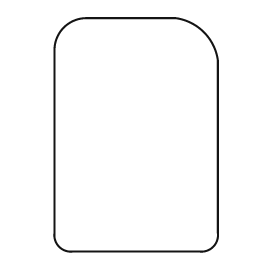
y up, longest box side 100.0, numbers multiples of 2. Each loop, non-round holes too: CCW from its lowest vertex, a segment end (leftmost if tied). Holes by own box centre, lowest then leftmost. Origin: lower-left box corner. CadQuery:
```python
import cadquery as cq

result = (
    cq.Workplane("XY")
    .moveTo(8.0, 0.0)
    .lineTo(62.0, 0.0)
    .threePointArc((68.0, 2.0), (70.0, 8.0))
    .lineTo(70.0, 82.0)
    .threePointArc((64.0, 94.0), (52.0, 100.0))
    .lineTo(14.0, 100.0)
    .threePointArc((4.0, 96.0), (0.0, 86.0))
    .lineTo(0.0, 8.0)
    .threePointArc((2.0, 2.0), (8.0, 0.0))
    .close()
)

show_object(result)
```